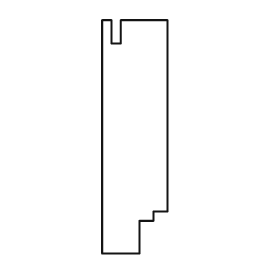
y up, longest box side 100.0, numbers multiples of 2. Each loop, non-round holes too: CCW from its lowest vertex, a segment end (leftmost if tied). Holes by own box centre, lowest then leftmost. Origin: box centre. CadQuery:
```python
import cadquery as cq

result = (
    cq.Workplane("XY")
    .moveTo(-14.0, -50.0)
    .lineTo(2.0, -50.0)
    .lineTo(2.0, -36.0)
    .lineTo(8.0, -36.0)
    .lineTo(8.0, -32.0)
    .lineTo(14.0, -32.0)
    .lineTo(14.0, 50.0)
    .lineTo(-6.0, 50.0)
    .lineTo(-6.0, 40.0)
    .lineTo(-10.0, 40.0)
    .lineTo(-10.0, 50.0)
    .lineTo(-14.0, 50.0)
    .close()
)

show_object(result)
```